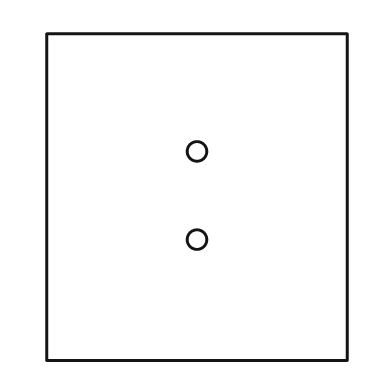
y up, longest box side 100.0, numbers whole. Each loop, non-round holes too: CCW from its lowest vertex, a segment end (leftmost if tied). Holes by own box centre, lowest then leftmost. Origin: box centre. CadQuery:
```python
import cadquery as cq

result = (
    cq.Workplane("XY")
    .moveTo(-46.0, -50.0)
    .lineTo(46.0, -50.0)
    .lineTo(46.0, 50.0)
    .lineTo(-46.0, 50.0)
    .close()
    .moveTo(0.0, -13.0)
    .circle(3.0)
    .moveTo(0.0, 14.0)
    .circle(3.0)
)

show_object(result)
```